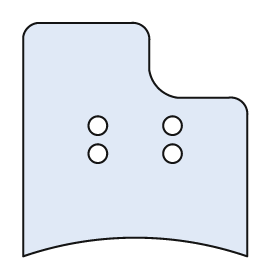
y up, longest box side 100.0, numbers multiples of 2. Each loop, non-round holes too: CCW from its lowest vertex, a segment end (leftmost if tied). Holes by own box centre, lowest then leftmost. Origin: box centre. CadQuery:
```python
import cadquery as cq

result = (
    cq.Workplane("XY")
    .moveTo(-48.0, -50.0)
    .threePointArc((0.0, -42.0), (48.0, -50.0))
    .lineTo(48.0, 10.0)
    .threePointArc((46.0, 16.0), (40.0, 18.0))
    .lineTo(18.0, 18.0)
    .threePointArc((10.0, 22.0), (6.0, 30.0))
    .lineTo(6.0, 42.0)
    .threePointArc((4.0, 48.0), (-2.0, 50.0))
    .lineTo(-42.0, 50.0)
    .threePointArc((-46.0, 48.0), (-48.0, 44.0))
    .close()
    .moveTo(-16.0, -6.0)
    .circle(4.0)
    .moveTo(16.0, -6.0)
    .circle(4.0)
    .moveTo(-16.0, 6.0)
    .circle(4.0)
    .moveTo(16.0, 6.0)
    .circle(4.0)
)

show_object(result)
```